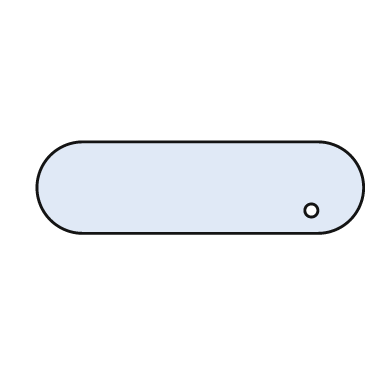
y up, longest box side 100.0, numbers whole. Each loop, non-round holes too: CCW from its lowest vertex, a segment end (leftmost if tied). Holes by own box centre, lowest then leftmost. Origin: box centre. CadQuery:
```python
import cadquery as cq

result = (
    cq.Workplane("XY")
    .moveTo(-36.0, -14.0)
    .lineTo(36.0, -14.0)
    .threePointArc((50.0, 0.0), (36.0, 14.0))
    .lineTo(-36.0, 14.0)
    .threePointArc((-50.0, 0.0), (-36.0, -14.0))
    .close()
    .moveTo(34.0, -7.0)
    .circle(2.0)
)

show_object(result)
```